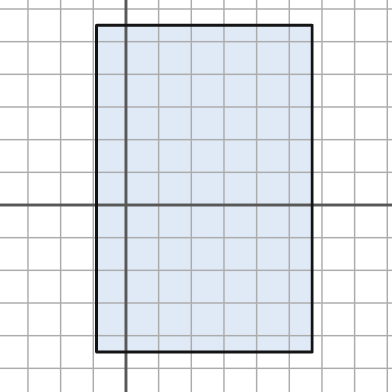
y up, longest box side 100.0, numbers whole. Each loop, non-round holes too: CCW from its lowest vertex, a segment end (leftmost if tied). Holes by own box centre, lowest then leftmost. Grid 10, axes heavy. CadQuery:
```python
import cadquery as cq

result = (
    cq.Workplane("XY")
    .moveTo(-9.0, -45.0)
    .lineTo(57.0, -45.0)
    .lineTo(57.0, 55.0)
    .lineTo(-9.0, 55.0)
    .close()
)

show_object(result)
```